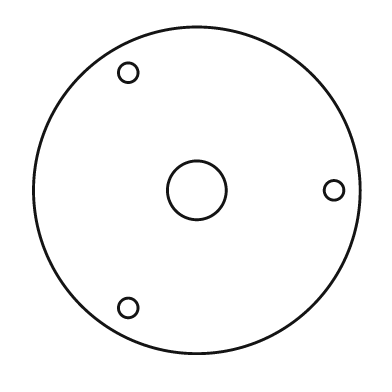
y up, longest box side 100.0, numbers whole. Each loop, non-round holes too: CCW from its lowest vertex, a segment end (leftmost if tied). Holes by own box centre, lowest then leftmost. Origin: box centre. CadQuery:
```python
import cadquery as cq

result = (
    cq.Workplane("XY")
    .moveTo(0.0, 0.0)
    .circle(50.0)
    .moveTo(-21.0, -36.0)
    .circle(3.0)
    .moveTo(0.0, 0.0)
    .circle(9.0)
    .moveTo(42.0, 0.0)
    .circle(3.0)
    .moveTo(-21.0, 36.0)
    .circle(3.0)
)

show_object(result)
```